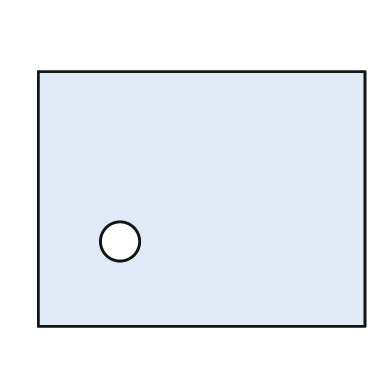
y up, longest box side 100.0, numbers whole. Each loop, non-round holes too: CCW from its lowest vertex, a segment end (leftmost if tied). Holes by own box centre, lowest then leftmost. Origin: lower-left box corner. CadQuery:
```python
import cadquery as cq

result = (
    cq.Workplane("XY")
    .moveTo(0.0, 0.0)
    .lineTo(100.0, 0.0)
    .lineTo(100.0, 78.0)
    .lineTo(0.0, 78.0)
    .close()
    .moveTo(25.0, 26.0)
    .circle(6.0)
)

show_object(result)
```